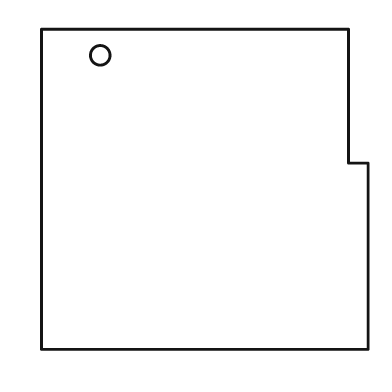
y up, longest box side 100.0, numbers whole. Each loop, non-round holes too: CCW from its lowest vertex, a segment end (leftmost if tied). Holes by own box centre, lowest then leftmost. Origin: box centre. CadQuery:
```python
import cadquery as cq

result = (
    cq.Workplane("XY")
    .moveTo(-50.0, -49.0)
    .lineTo(50.0, -49.0)
    .lineTo(50.0, 8.0)
    .lineTo(44.0, 8.0)
    .lineTo(44.0, 49.0)
    .lineTo(-50.0, 49.0)
    .close()
    .moveTo(-32.0, 41.0)
    .circle(3.0)
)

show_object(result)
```